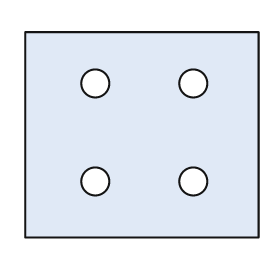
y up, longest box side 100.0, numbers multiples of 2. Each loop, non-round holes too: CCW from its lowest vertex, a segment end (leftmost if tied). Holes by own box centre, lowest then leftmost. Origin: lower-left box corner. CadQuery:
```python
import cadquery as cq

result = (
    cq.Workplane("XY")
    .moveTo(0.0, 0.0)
    .lineTo(100.0, 0.0)
    .lineTo(100.0, 88.0)
    .lineTo(0.0, 88.0)
    .close()
    .moveTo(30.0, 24.0)
    .circle(6.0)
    .moveTo(72.0, 24.0)
    .circle(6.0)
    .moveTo(30.0, 66.0)
    .circle(6.0)
    .moveTo(72.0, 66.0)
    .circle(6.0)
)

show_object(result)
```